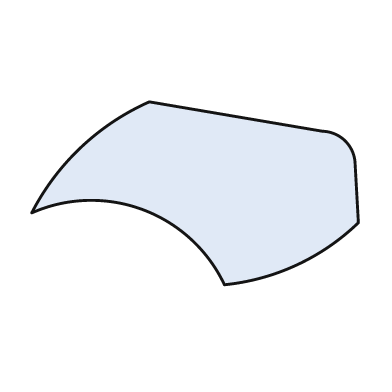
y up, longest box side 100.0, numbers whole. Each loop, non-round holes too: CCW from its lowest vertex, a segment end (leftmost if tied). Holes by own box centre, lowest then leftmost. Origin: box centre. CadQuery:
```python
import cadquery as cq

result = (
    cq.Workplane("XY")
    .moveTo(9.0, -28.0)
    .threePointArc((31.0, -22.0), (50.0, -9.0))
    .lineTo(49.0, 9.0)
    .threePointArc((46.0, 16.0), (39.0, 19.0))
    .lineTo(-14.0, 28.0)
    .threePointArc((-35.0, 14.0), (-50.0, -6.0))
    .threePointArc((-16.0, -5.0), (9.0, -28.0))
    .close()
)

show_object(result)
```